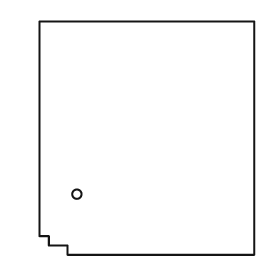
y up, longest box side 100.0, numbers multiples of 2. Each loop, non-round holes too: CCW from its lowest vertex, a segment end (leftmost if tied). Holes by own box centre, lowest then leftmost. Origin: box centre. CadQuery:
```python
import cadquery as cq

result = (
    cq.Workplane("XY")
    .moveTo(-34.0, -50.0)
    .lineTo(46.0, -50.0)
    .lineTo(46.0, 50.0)
    .lineTo(-46.0, 50.0)
    .lineTo(-46.0, -42.0)
    .lineTo(-42.0, -42.0)
    .lineTo(-42.0, -46.0)
    .lineTo(-34.0, -46.0)
    .close()
    .moveTo(-30.0, -24.0)
    .circle(2.0)
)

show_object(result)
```